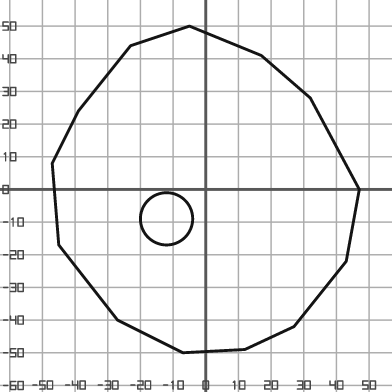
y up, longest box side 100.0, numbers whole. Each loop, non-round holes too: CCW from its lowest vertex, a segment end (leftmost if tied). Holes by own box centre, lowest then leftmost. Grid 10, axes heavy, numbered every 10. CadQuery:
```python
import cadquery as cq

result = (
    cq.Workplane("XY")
    .moveTo(-7.0, -50.0)
    .lineTo(12.0, -49.0)
    .lineTo(27.0, -42.0)
    .lineTo(43.0, -22.0)
    .lineTo(47.0, 0.0)
    .lineTo(32.0, 28.0)
    .lineTo(17.0, 41.0)
    .lineTo(-5.0, 50.0)
    .lineTo(-23.0, 44.0)
    .lineTo(-39.0, 24.0)
    .lineTo(-47.0, 8.0)
    .lineTo(-45.0, -17.0)
    .lineTo(-27.0, -40.0)
    .close()
    .moveTo(-12.0, -9.0)
    .circle(8.0)
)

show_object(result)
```